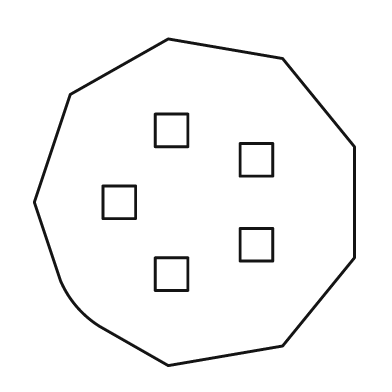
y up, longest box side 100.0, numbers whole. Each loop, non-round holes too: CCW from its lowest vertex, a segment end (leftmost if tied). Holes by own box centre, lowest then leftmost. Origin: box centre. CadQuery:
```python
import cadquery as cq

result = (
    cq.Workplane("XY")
    .moveTo(-8.0, -50.0)
    .lineTo(27.0, -44.0)
    .lineTo(49.0, -17.0)
    .lineTo(49.0, 17.0)
    .lineTo(27.0, 44.0)
    .lineTo(-8.0, 50.0)
    .lineTo(-38.0, 33.0)
    .lineTo(-49.0, 0.0)
    .lineTo(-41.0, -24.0)
    .threePointArc((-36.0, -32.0), (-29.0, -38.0))
    .close()
    .moveTo(-12.0, -27.0)
    .lineTo(-2.0, -27.0)
    .lineTo(-2.0, -17.0)
    .lineTo(-12.0, -17.0)
    .close()
    .moveTo(14.0, -18.0)
    .lineTo(24.0, -18.0)
    .lineTo(24.0, -8.0)
    .lineTo(14.0, -8.0)
    .close()
    .moveTo(-28.0, -5.0)
    .lineTo(-18.0, -5.0)
    .lineTo(-18.0, 5.0)
    .lineTo(-28.0, 5.0)
    .close()
    .moveTo(14.0, 8.0)
    .lineTo(24.0, 8.0)
    .lineTo(24.0, 18.0)
    .lineTo(14.0, 18.0)
    .close()
    .moveTo(-12.0, 17.0)
    .lineTo(-2.0, 17.0)
    .lineTo(-2.0, 27.0)
    .lineTo(-12.0, 27.0)
    .close()
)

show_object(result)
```